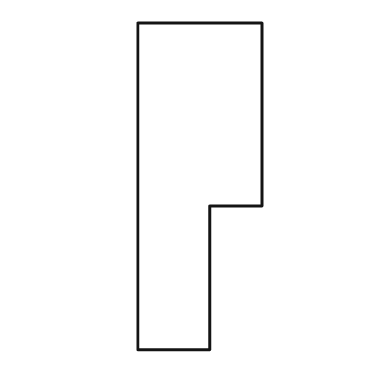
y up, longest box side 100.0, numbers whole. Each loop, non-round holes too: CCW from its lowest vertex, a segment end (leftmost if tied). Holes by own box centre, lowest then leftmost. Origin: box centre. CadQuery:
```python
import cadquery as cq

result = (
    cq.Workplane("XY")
    .moveTo(-19.0, -50.0)
    .lineTo(3.0, -50.0)
    .lineTo(3.0, -6.0)
    .lineTo(19.0, -6.0)
    .lineTo(19.0, 50.0)
    .lineTo(-19.0, 50.0)
    .close()
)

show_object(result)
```